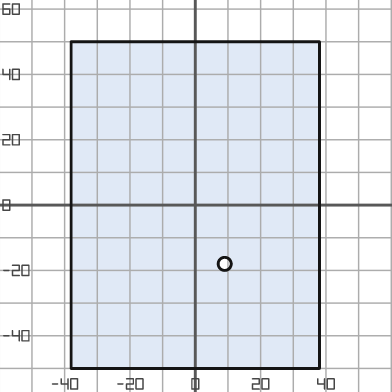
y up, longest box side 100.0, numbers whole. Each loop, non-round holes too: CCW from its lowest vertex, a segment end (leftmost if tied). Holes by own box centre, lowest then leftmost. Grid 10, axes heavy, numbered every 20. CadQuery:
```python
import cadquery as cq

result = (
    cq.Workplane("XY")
    .moveTo(-38.0, -50.0)
    .lineTo(38.0, -50.0)
    .lineTo(38.0, 50.0)
    .lineTo(-38.0, 50.0)
    .close()
    .moveTo(9.0, -18.0)
    .circle(2.0)
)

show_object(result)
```